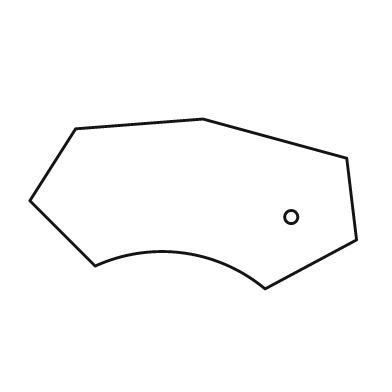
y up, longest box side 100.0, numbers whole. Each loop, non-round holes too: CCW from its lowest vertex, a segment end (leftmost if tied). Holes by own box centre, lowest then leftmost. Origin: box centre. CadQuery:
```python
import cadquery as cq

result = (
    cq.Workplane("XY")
    .moveTo(22.0, -26.0)
    .lineTo(50.0, -11.0)
    .lineTo(47.0, 14.0)
    .lineTo(3.0, 26.0)
    .lineTo(-36.0, 23.0)
    .lineTo(-50.0, 1.0)
    .lineTo(-30.0, -19.0)
    .threePointArc((-3.0, -15.0), (22.0, -26.0))
    .close()
    .moveTo(30.0, -4.0)
    .circle(2.0)
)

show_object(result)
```